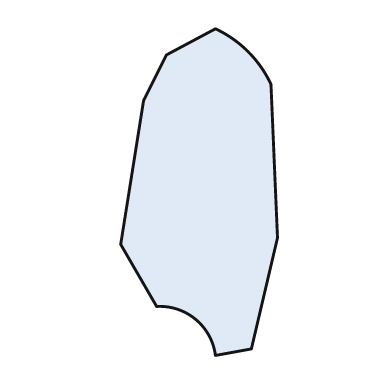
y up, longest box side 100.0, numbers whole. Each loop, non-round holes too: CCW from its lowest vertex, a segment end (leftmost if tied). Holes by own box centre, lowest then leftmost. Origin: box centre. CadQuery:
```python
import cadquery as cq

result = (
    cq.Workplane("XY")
    .moveTo(5.0, -50.0)
    .lineTo(16.0, -48.0)
    .lineTo(24.0, -14.0)
    .lineTo(22.0, 33.0)
    .threePointArc((15.0, 43.0), (5.0, 50.0))
    .lineTo(-10.0, 42.0)
    .lineTo(-17.0, 28.0)
    .lineTo(-24.0, -16.0)
    .lineTo(-13.0, -35.0)
    .threePointArc((-1.0, -39.0), (5.0, -50.0))
    .close()
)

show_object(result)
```